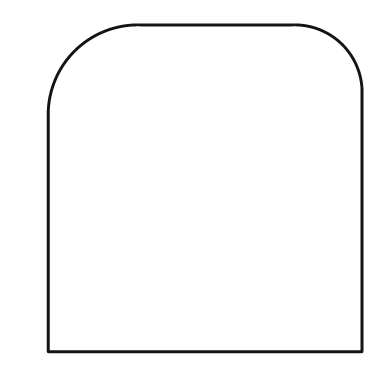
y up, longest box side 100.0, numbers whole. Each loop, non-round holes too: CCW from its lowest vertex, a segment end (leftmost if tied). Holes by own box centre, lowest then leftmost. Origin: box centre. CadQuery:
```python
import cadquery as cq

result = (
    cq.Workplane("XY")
    .moveTo(-48.0, -50.0)
    .lineTo(48.0, -50.0)
    .lineTo(48.0, 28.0)
    .threePointArc((42.0, 44.0), (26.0, 50.0))
    .lineTo(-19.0, 50.0)
    .threePointArc((-40.0, 42.0), (-48.0, 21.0))
    .close()
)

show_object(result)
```